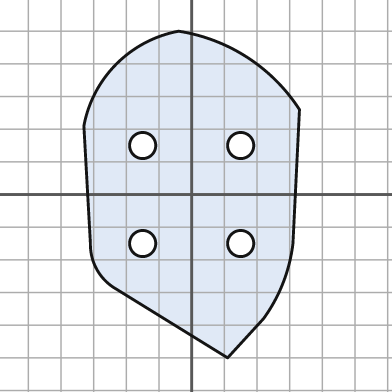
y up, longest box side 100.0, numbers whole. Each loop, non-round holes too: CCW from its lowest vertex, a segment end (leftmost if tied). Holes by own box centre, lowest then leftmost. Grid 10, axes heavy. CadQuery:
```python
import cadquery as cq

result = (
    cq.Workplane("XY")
    .moveTo(11.0, -50.0)
    .lineTo(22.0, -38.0)
    .threePointArc((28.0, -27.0), (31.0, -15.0))
    .lineTo(33.0, 26.0)
    .threePointArc((17.0, 42.0), (-4.0, 50.0))
    .threePointArc((-23.0, 40.0), (-33.0, 21.0))
    .lineTo(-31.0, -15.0)
    .threePointArc((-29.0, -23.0), (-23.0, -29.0))
    .close()
    .moveTo(-15.0, -15.0)
    .circle(4.0)
    .moveTo(15.0, -15.0)
    .circle(4.0)
    .moveTo(-15.0, 15.0)
    .circle(4.0)
    .moveTo(15.0, 15.0)
    .circle(4.0)
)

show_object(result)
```